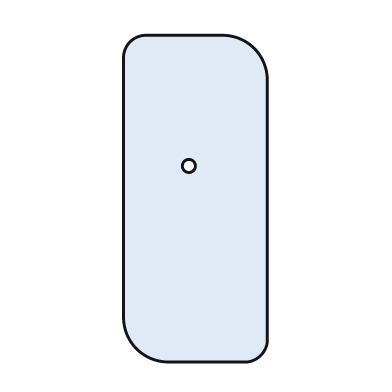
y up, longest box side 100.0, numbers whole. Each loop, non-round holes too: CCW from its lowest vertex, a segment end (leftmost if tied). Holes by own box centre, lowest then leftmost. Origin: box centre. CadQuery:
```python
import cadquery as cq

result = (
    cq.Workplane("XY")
    .moveTo(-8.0, -50.0)
    .lineTo(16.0, -50.0)
    .threePointArc((20.0, -48.0), (22.0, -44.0))
    .lineTo(22.0, 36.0)
    .threePointArc((18.0, 46.0), (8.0, 50.0))
    .lineTo(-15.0, 50.0)
    .threePointArc((-20.0, 48.0), (-22.0, 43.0))
    .lineTo(-22.0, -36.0)
    .threePointArc((-18.0, -46.0), (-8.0, -50.0))
    .close()
    .moveTo(-2.0, 10.0)
    .circle(2.0)
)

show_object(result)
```